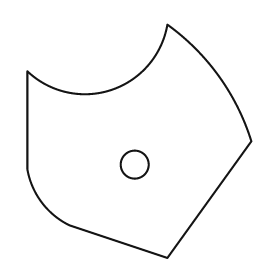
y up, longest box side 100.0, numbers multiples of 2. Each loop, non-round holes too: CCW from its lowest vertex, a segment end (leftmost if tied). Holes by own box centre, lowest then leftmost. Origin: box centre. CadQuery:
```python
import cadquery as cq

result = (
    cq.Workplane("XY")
    .moveTo(12.0, -50.0)
    .lineTo(48.0, 0.0)
    .threePointArc((34.0, 28.0), (12.0, 50.0))
    .threePointArc((-12.0, 22.0), (-48.0, 30.0))
    .lineTo(-48.0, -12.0)
    .threePointArc((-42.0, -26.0), (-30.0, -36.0))
    .close()
    .moveTo(-2.0, -10.0)
    .circle(6.0)
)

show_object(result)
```